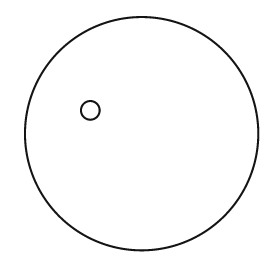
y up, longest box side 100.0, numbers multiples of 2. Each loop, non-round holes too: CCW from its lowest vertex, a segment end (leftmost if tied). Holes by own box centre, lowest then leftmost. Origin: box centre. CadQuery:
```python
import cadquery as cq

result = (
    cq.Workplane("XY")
    .moveTo(0.0, 0.0)
    .circle(50.0)
    .moveTo(-22.0, 10.0)
    .circle(4.0)
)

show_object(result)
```